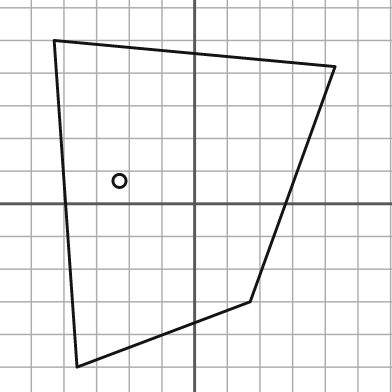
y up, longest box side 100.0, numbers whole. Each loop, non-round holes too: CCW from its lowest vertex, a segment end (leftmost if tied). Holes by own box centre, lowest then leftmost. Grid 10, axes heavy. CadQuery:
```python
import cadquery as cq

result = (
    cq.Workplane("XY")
    .moveTo(-36.0, -50.0)
    .lineTo(17.0, -30.0)
    .lineTo(43.0, 42.0)
    .lineTo(-43.0, 50.0)
    .close()
    .moveTo(-23.0, 7.0)
    .circle(2.0)
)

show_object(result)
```